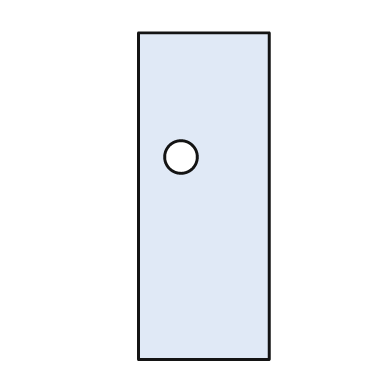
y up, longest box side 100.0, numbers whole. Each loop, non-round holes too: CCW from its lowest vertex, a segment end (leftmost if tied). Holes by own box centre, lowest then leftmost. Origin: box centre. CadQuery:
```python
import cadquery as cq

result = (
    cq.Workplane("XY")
    .moveTo(-20.0, -50.0)
    .lineTo(20.0, -50.0)
    .lineTo(20.0, 50.0)
    .lineTo(-20.0, 50.0)
    .close()
    .moveTo(-7.0, 12.0)
    .circle(5.0)
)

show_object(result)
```